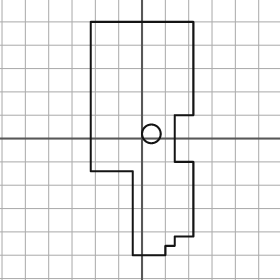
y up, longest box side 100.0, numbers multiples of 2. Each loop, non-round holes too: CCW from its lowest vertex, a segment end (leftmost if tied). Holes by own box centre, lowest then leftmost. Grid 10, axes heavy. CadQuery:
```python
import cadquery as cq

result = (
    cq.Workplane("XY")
    .moveTo(-4.0, -50.0)
    .lineTo(10.0, -50.0)
    .lineTo(10.0, -46.0)
    .lineTo(14.0, -46.0)
    .lineTo(14.0, -42.0)
    .lineTo(22.0, -42.0)
    .lineTo(22.0, -10.0)
    .lineTo(14.0, -10.0)
    .lineTo(14.0, 10.0)
    .lineTo(22.0, 10.0)
    .lineTo(22.0, 50.0)
    .lineTo(-22.0, 50.0)
    .lineTo(-22.0, -14.0)
    .lineTo(-4.0, -14.0)
    .close()
    .moveTo(4.0, 2.0)
    .circle(4.0)
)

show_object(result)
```